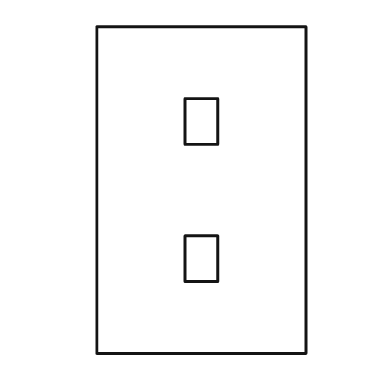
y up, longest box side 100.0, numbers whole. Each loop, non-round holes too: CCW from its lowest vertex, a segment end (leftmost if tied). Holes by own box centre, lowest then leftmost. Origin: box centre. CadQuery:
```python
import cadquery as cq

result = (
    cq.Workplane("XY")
    .moveTo(-32.0, -50.0)
    .lineTo(32.0, -50.0)
    .lineTo(32.0, 50.0)
    .lineTo(-32.0, 50.0)
    .close()
    .moveTo(-5.0, -28.0)
    .lineTo(5.0, -28.0)
    .lineTo(5.0, -14.0)
    .lineTo(-5.0, -14.0)
    .close()
    .moveTo(-5.0, 14.0)
    .lineTo(5.0, 14.0)
    .lineTo(5.0, 28.0)
    .lineTo(-5.0, 28.0)
    .close()
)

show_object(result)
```